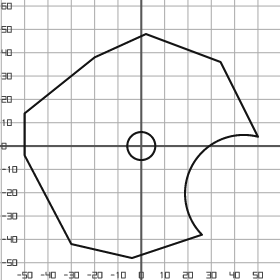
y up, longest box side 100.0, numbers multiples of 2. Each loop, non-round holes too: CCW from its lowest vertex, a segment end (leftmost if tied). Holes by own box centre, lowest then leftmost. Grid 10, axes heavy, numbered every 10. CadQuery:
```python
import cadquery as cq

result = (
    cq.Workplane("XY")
    .moveTo(-4.0, -48.0)
    .lineTo(26.0, -38.0)
    .threePointArc((22.0, -8.0), (50.0, 4.0))
    .lineTo(34.0, 36.0)
    .lineTo(2.0, 48.0)
    .lineTo(-20.0, 38.0)
    .lineTo(-50.0, 14.0)
    .lineTo(-50.0, -4.0)
    .lineTo(-30.0, -42.0)
    .close()
    .moveTo(0.0, 0.0)
    .circle(6.0)
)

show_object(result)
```